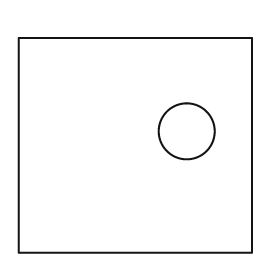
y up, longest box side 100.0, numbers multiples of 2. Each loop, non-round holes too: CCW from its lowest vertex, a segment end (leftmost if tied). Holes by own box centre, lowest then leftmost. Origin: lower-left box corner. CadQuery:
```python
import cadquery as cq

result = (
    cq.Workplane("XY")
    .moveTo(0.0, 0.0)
    .lineTo(100.0, 0.0)
    .lineTo(100.0, 92.0)
    .lineTo(0.0, 92.0)
    .close()
    .moveTo(72.0, 52.0)
    .circle(12.0)
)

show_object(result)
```